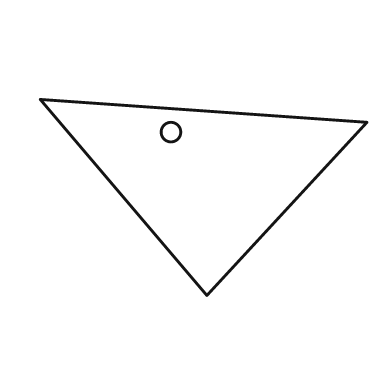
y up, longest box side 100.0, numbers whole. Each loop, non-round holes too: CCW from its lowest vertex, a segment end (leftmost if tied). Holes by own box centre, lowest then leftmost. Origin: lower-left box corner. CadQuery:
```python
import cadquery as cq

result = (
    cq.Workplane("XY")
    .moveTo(51.0, 0.0)
    .lineTo(100.0, 53.0)
    .lineTo(0.0, 60.0)
    .close()
    .moveTo(40.0, 50.0)
    .circle(3.0)
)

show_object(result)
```